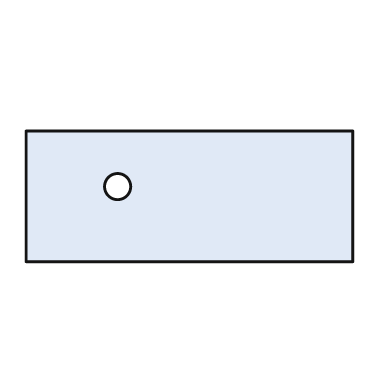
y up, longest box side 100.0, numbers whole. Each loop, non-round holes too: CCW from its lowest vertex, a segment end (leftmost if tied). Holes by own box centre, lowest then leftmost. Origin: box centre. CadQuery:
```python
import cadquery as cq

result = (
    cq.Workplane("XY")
    .moveTo(-50.0, -20.0)
    .lineTo(50.0, -20.0)
    .lineTo(50.0, 20.0)
    .lineTo(-50.0, 20.0)
    .close()
    .moveTo(-22.0, 3.0)
    .circle(4.0)
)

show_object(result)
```